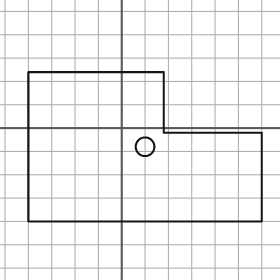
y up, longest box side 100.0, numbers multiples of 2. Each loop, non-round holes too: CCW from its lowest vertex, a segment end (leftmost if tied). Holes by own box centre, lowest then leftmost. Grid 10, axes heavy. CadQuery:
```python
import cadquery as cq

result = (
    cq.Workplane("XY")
    .moveTo(-40.0, -40.0)
    .lineTo(60.0, -40.0)
    .lineTo(60.0, -2.0)
    .lineTo(18.0, -2.0)
    .lineTo(18.0, 24.0)
    .lineTo(-40.0, 24.0)
    .close()
    .moveTo(10.0, -8.0)
    .circle(4.0)
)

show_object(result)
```